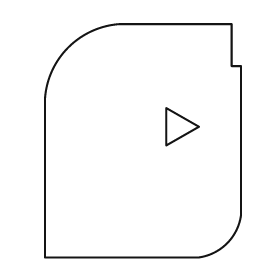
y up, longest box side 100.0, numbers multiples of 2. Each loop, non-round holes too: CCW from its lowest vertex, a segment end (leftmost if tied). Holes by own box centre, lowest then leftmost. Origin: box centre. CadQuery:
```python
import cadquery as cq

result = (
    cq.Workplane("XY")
    .moveTo(-42.0, -50.0)
    .lineTo(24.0, -50.0)
    .threePointArc((36.0, -44.0), (42.0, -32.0))
    .lineTo(42.0, 32.0)
    .lineTo(38.0, 32.0)
    .lineTo(38.0, 50.0)
    .lineTo(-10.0, 50.0)
    .threePointArc((-32.0, 40.0), (-42.0, 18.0))
    .close()
    .moveTo(10.0, -2.0)
    .lineTo(24.0, 6.0)
    .lineTo(10.0, 14.0)
    .close()
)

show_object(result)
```